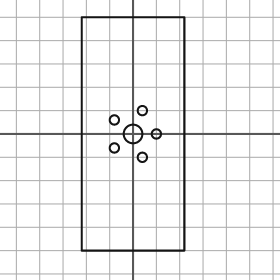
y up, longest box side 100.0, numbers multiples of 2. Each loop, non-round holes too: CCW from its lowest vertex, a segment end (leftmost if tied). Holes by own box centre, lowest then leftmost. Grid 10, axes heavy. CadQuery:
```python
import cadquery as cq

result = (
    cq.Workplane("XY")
    .moveTo(-22.0, -50.0)
    .lineTo(22.0, -50.0)
    .lineTo(22.0, 50.0)
    .lineTo(-22.0, 50.0)
    .close()
    .moveTo(4.0, -10.0)
    .circle(2.0)
    .moveTo(-8.0, -6.0)
    .circle(2.0)
    .moveTo(0.0, 0.0)
    .circle(4.0)
    .moveTo(10.0, 0.0)
    .circle(2.0)
    .moveTo(-8.0, 6.0)
    .circle(2.0)
    .moveTo(4.0, 10.0)
    .circle(2.0)
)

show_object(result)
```